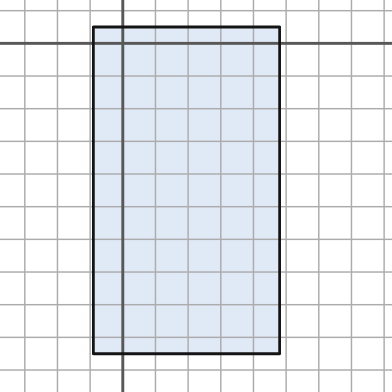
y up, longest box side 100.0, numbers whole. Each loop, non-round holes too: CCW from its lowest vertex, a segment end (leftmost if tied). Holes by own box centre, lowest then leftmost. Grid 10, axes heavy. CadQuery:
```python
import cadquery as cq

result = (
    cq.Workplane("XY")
    .moveTo(-9.0, -95.0)
    .lineTo(48.0, -95.0)
    .lineTo(48.0, 5.0)
    .lineTo(-9.0, 5.0)
    .close()
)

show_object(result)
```